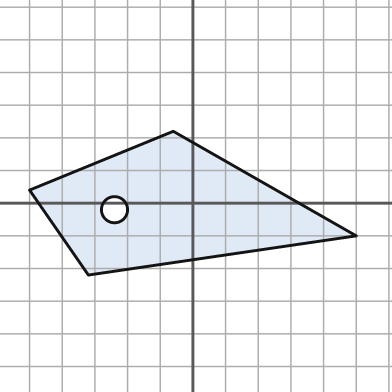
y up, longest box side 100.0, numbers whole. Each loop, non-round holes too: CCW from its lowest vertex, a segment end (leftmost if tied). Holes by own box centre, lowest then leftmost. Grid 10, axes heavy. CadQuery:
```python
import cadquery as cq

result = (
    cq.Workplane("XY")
    .moveTo(-32.0, -22.0)
    .lineTo(50.0, -10.0)
    .lineTo(-6.0, 22.0)
    .lineTo(-50.0, 4.0)
    .close()
    .moveTo(-24.0, -2.0)
    .circle(4.0)
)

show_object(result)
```